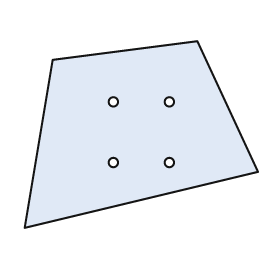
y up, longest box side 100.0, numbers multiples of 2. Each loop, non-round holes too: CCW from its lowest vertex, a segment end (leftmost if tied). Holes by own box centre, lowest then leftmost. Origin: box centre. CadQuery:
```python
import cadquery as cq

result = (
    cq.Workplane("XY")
    .moveTo(-50.0, -40.0)
    .lineTo(50.0, -16.0)
    .lineTo(24.0, 40.0)
    .lineTo(-38.0, 32.0)
    .close()
    .moveTo(-12.0, -12.0)
    .circle(2.0)
    .moveTo(12.0, -12.0)
    .circle(2.0)
    .moveTo(-12.0, 14.0)
    .circle(2.0)
    .moveTo(12.0, 14.0)
    .circle(2.0)
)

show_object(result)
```